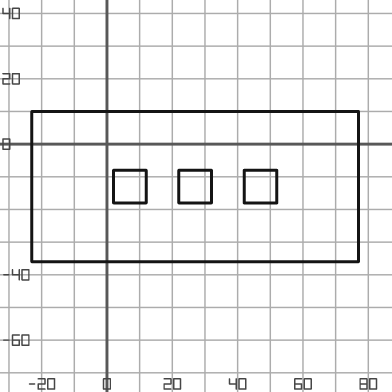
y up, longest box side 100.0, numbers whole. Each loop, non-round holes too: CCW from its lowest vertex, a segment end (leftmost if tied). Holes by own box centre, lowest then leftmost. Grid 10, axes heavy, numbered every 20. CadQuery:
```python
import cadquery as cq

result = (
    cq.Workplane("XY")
    .moveTo(-23.0, -36.0)
    .lineTo(77.0, -36.0)
    .lineTo(77.0, 10.0)
    .lineTo(-23.0, 10.0)
    .close()
    .moveTo(2.0, -18.0)
    .lineTo(12.0, -18.0)
    .lineTo(12.0, -8.0)
    .lineTo(2.0, -8.0)
    .close()
    .moveTo(22.0, -18.0)
    .lineTo(32.0, -18.0)
    .lineTo(32.0, -8.0)
    .lineTo(22.0, -8.0)
    .close()
    .moveTo(42.0, -18.0)
    .lineTo(52.0, -18.0)
    .lineTo(52.0, -8.0)
    .lineTo(42.0, -8.0)
    .close()
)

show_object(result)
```